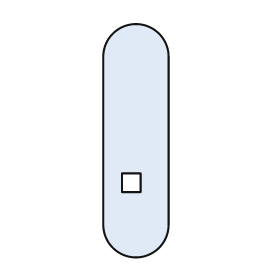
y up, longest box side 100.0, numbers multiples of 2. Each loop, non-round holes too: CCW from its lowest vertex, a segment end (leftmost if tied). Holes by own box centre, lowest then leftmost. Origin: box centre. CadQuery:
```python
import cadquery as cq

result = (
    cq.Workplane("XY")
    .moveTo(-14.0, -36.0)
    .threePointArc((0.0, -50.0), (14.0, -36.0))
    .lineTo(14.0, 36.0)
    .threePointArc((0.0, 50.0), (-14.0, 36.0))
    .close()
    .moveTo(-6.0, -22.0)
    .lineTo(2.0, -22.0)
    .lineTo(2.0, -14.0)
    .lineTo(-6.0, -14.0)
    .close()
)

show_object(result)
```